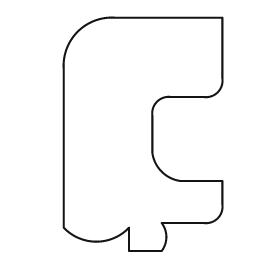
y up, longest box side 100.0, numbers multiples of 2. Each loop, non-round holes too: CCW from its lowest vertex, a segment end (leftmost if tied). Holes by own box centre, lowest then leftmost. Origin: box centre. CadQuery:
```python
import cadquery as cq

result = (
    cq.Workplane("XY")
    .moveTo(-6.0, -50.0)
    .lineTo(8.0, -50.0)
    .threePointArc((10.0, -44.0), (8.0, -38.0))
    .lineTo(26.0, -38.0)
    .threePointArc((32.0, -36.0), (34.0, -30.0))
    .lineTo(34.0, -20.0)
    .lineTo(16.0, -20.0)
    .threePointArc((8.0, -16.0), (4.0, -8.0))
    .lineTo(4.0, 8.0)
    .threePointArc((6.0, 14.0), (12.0, 16.0))
    .lineTo(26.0, 16.0)
    .threePointArc((32.0, 18.0), (34.0, 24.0))
    .lineTo(34.0, 50.0)
    .lineTo(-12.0, 50.0)
    .threePointArc((-28.0, 44.0), (-34.0, 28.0))
    .lineTo(-34.0, -40.0)
    .threePointArc((-20.0, -46.0), (-6.0, -40.0))
    .close()
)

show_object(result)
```